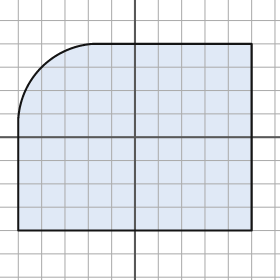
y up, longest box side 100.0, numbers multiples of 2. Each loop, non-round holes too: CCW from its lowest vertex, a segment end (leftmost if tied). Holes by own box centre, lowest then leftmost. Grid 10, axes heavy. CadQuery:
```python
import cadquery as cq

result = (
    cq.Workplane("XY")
    .moveTo(-50.0, -40.0)
    .lineTo(50.0, -40.0)
    .lineTo(50.0, 40.0)
    .lineTo(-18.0, 40.0)
    .threePointArc((-40.0, 30.0), (-50.0, 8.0))
    .close()
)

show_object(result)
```